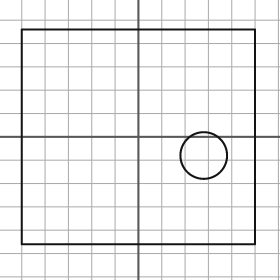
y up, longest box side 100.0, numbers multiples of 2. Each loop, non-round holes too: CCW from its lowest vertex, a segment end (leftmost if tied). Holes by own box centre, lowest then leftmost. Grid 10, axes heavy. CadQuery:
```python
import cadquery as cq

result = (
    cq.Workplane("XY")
    .moveTo(-50.0, -46.0)
    .lineTo(50.0, -46.0)
    .lineTo(50.0, 46.0)
    .lineTo(-50.0, 46.0)
    .close()
    .moveTo(28.0, -8.0)
    .circle(10.0)
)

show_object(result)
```